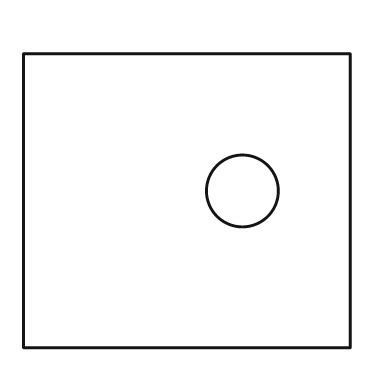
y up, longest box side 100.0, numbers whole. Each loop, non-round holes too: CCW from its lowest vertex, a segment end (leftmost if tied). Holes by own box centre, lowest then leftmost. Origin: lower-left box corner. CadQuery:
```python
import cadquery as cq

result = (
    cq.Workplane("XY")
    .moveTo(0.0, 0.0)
    .lineTo(100.0, 0.0)
    .lineTo(100.0, 90.0)
    .lineTo(0.0, 90.0)
    .close()
    .moveTo(67.0, 48.0)
    .circle(11.0)
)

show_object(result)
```